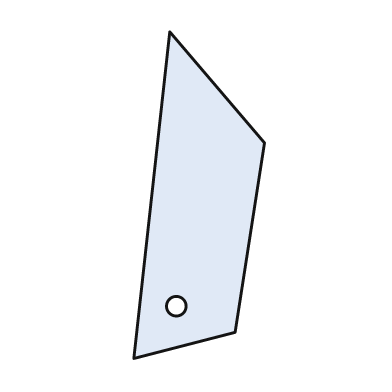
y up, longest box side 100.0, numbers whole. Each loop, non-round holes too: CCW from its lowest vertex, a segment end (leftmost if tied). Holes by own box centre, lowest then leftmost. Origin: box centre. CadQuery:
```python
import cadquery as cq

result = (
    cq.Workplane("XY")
    .moveTo(-20.0, -50.0)
    .lineTo(11.0, -42.0)
    .lineTo(20.0, 16.0)
    .lineTo(-9.0, 50.0)
    .close()
    .moveTo(-7.0, -34.0)
    .circle(3.0)
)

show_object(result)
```